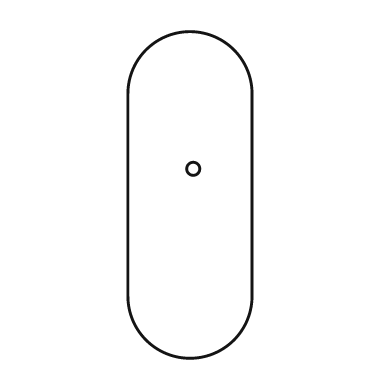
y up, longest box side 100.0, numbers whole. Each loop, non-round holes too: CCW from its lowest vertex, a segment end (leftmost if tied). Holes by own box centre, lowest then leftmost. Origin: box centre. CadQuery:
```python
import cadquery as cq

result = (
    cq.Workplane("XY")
    .moveTo(-19.0, -31.0)
    .threePointArc((0.0, -50.0), (19.0, -31.0))
    .lineTo(19.0, 31.0)
    .threePointArc((0.0, 50.0), (-19.0, 31.0))
    .close()
    .moveTo(1.0, 8.0)
    .circle(2.0)
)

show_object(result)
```